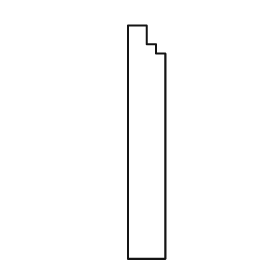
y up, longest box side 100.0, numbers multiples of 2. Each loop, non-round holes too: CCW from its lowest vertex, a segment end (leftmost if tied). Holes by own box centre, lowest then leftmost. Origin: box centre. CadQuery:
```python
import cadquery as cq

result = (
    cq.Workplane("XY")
    .moveTo(-8.0, -50.0)
    .lineTo(8.0, -50.0)
    .lineTo(8.0, 38.0)
    .lineTo(4.0, 38.0)
    .lineTo(4.0, 42.0)
    .lineTo(0.0, 42.0)
    .lineTo(0.0, 50.0)
    .lineTo(-8.0, 50.0)
    .close()
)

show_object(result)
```